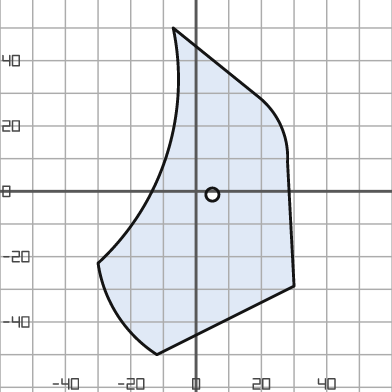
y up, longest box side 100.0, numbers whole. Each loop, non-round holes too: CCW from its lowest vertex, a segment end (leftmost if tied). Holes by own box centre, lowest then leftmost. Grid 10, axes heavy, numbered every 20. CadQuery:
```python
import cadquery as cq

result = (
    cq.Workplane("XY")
    .moveTo(-12.0, -50.0)
    .lineTo(30.0, -29.0)
    .lineTo(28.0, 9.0)
    .threePointArc((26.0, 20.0), (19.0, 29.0))
    .lineTo(-7.0, 50.0)
    .threePointArc((-9.0, 11.0), (-30.0, -22.0))
    .threePointArc((-24.0, -38.0), (-12.0, -50.0))
    .close()
    .moveTo(5.0, -1.0)
    .circle(2.0)
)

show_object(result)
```